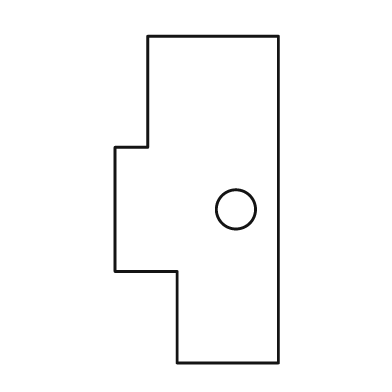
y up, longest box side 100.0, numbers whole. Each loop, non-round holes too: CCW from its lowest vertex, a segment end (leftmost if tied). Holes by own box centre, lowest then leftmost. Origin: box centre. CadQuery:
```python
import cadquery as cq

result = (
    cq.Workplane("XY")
    .moveTo(-6.0, -50.0)
    .lineTo(25.0, -50.0)
    .lineTo(25.0, 50.0)
    .lineTo(-15.0, 50.0)
    .lineTo(-15.0, 16.0)
    .lineTo(-25.0, 16.0)
    .lineTo(-25.0, -22.0)
    .lineTo(-6.0, -22.0)
    .close()
    .moveTo(12.0, -3.0)
    .circle(6.0)
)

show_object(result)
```